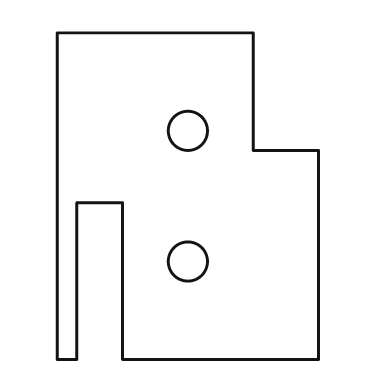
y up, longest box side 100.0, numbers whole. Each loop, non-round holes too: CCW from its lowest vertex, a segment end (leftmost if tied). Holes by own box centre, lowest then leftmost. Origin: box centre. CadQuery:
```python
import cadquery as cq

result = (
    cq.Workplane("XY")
    .moveTo(-40.0, -50.0)
    .lineTo(-34.0, -50.0)
    .lineTo(-34.0, -2.0)
    .lineTo(-20.0, -2.0)
    .lineTo(-20.0, -50.0)
    .lineTo(40.0, -50.0)
    .lineTo(40.0, 14.0)
    .lineTo(20.0, 14.0)
    .lineTo(20.0, 50.0)
    .lineTo(-40.0, 50.0)
    .close()
    .moveTo(0.0, -20.0)
    .circle(6.0)
    .moveTo(0.0, 20.0)
    .circle(6.0)
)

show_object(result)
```